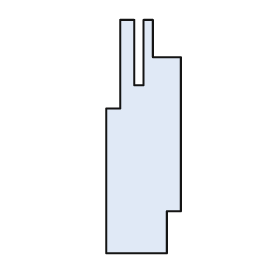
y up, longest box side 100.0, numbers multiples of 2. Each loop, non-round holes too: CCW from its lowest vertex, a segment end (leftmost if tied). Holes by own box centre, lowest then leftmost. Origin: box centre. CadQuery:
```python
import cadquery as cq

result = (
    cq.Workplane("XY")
    .moveTo(-16.0, -50.0)
    .lineTo(10.0, -50.0)
    .lineTo(10.0, -32.0)
    .lineTo(16.0, -32.0)
    .lineTo(16.0, 34.0)
    .lineTo(4.0, 34.0)
    .lineTo(4.0, 50.0)
    .lineTo(0.0, 50.0)
    .lineTo(0.0, 22.0)
    .lineTo(-4.0, 22.0)
    .lineTo(-4.0, 50.0)
    .lineTo(-10.0, 50.0)
    .lineTo(-10.0, 12.0)
    .lineTo(-16.0, 12.0)
    .close()
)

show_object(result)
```